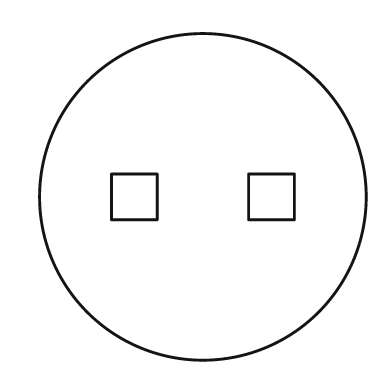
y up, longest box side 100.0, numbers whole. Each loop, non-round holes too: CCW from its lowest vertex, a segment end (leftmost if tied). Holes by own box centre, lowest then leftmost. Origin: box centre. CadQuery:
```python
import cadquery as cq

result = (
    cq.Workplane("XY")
    .moveTo(0.0, 0.0)
    .circle(50.0)
    .moveTo(-28.0, -7.0)
    .lineTo(-14.0, -7.0)
    .lineTo(-14.0, 7.0)
    .lineTo(-28.0, 7.0)
    .close()
    .moveTo(14.0, -7.0)
    .lineTo(28.0, -7.0)
    .lineTo(28.0, 7.0)
    .lineTo(14.0, 7.0)
    .close()
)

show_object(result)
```